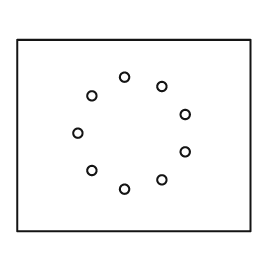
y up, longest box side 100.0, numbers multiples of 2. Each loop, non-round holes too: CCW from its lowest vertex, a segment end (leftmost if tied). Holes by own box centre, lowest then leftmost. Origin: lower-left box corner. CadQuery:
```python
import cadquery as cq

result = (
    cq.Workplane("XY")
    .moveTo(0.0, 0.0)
    .lineTo(100.0, 0.0)
    .lineTo(100.0, 82.0)
    .lineTo(0.0, 82.0)
    .close()
    .moveTo(46.0, 18.0)
    .circle(2.0)
    .moveTo(62.0, 22.0)
    .circle(2.0)
    .moveTo(32.0, 26.0)
    .circle(2.0)
    .moveTo(72.0, 34.0)
    .circle(2.0)
    .moveTo(26.0, 42.0)
    .circle(2.0)
    .moveTo(72.0, 50.0)
    .circle(2.0)
    .moveTo(32.0, 58.0)
    .circle(2.0)
    .moveTo(62.0, 62.0)
    .circle(2.0)
    .moveTo(46.0, 66.0)
    .circle(2.0)
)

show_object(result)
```